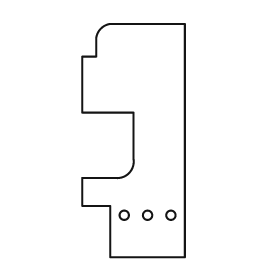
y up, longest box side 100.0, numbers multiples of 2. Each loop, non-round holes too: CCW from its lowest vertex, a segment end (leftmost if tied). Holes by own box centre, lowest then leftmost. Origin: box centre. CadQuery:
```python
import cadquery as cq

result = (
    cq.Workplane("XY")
    .moveTo(-10.0, -50.0)
    .lineTo(22.0, -50.0)
    .lineTo(22.0, 50.0)
    .lineTo(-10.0, 50.0)
    .threePointArc((-14.0, 48.0), (-16.0, 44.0))
    .lineTo(-16.0, 36.0)
    .lineTo(-22.0, 36.0)
    .lineTo(-22.0, 12.0)
    .lineTo(0.0, 12.0)
    .lineTo(0.0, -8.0)
    .threePointArc((-2.0, -14.0), (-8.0, -16.0))
    .lineTo(-22.0, -16.0)
    .lineTo(-22.0, -28.0)
    .lineTo(-10.0, -28.0)
    .close()
    .moveTo(-4.0, -32.0)
    .circle(2.0)
    .moveTo(6.0, -32.0)
    .circle(2.0)
    .moveTo(16.0, -32.0)
    .circle(2.0)
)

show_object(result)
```